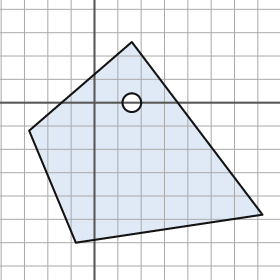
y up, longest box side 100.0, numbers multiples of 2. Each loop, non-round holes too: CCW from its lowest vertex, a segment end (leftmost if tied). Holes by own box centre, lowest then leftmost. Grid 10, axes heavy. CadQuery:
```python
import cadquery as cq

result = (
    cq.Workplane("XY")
    .moveTo(-8.0, -60.0)
    .lineTo(72.0, -48.0)
    .lineTo(16.0, 26.0)
    .lineTo(-28.0, -12.0)
    .close()
    .moveTo(16.0, 0.0)
    .circle(4.0)
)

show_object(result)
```